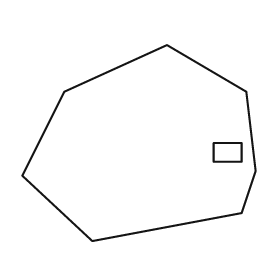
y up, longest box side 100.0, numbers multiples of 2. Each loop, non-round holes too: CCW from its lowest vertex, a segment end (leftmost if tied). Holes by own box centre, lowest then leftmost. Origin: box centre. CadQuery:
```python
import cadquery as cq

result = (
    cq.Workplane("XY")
    .moveTo(-20.0, -42.0)
    .lineTo(44.0, -30.0)
    .lineTo(50.0, -12.0)
    .lineTo(46.0, 22.0)
    .lineTo(12.0, 42.0)
    .lineTo(-32.0, 22.0)
    .lineTo(-50.0, -14.0)
    .close()
    .moveTo(32.0, -8.0)
    .lineTo(44.0, -8.0)
    .lineTo(44.0, 0.0)
    .lineTo(32.0, 0.0)
    .close()
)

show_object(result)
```